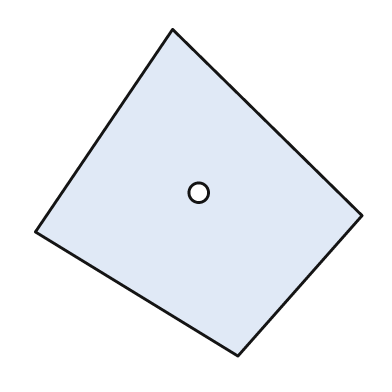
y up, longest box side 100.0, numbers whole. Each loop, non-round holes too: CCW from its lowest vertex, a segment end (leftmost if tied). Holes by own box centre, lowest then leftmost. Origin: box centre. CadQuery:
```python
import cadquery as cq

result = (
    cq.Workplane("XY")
    .moveTo(12.0, -50.0)
    .lineTo(50.0, -7.0)
    .lineTo(-8.0, 50.0)
    .lineTo(-50.0, -12.0)
    .close()
    .moveTo(0.0, 0.0)
    .circle(3.0)
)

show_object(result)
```